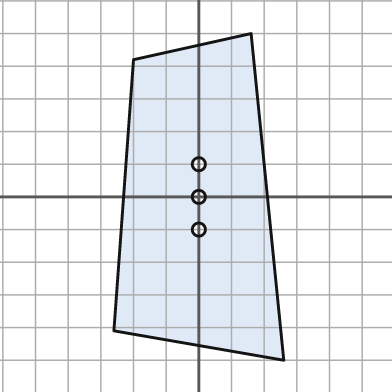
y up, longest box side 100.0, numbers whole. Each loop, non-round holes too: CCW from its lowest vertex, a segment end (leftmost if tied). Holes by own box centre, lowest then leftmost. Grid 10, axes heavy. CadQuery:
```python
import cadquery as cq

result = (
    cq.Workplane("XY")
    .moveTo(26.0, -50.0)
    .lineTo(16.0, 50.0)
    .lineTo(-20.0, 42.0)
    .lineTo(-26.0, -41.0)
    .close()
    .moveTo(0.0, -10.0)
    .circle(2.0)
    .moveTo(0.0, 0.0)
    .circle(2.0)
    .moveTo(0.0, 10.0)
    .circle(2.0)
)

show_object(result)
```